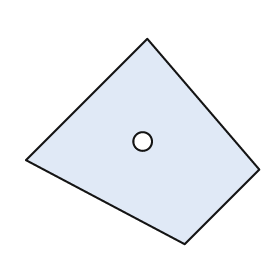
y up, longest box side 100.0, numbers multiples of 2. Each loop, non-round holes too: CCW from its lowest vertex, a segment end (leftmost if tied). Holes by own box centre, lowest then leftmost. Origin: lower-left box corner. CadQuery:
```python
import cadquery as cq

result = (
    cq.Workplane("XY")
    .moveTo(68.0, 0.0)
    .lineTo(100.0, 32.0)
    .lineTo(52.0, 88.0)
    .lineTo(0.0, 36.0)
    .close()
    .moveTo(50.0, 44.0)
    .circle(4.0)
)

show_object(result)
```